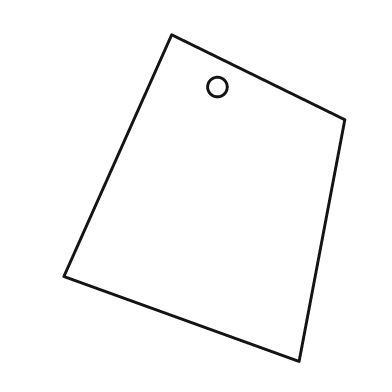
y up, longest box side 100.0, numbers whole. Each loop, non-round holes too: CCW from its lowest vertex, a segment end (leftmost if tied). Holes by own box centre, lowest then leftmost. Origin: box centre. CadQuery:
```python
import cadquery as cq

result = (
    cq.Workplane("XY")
    .moveTo(29.0, -50.0)
    .lineTo(43.0, 24.0)
    .lineTo(-10.0, 50.0)
    .lineTo(-43.0, -24.0)
    .close()
    .moveTo(4.0, 34.0)
    .circle(3.0)
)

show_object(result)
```